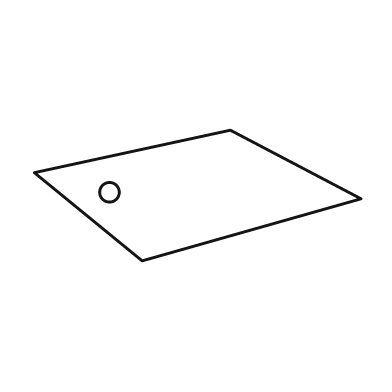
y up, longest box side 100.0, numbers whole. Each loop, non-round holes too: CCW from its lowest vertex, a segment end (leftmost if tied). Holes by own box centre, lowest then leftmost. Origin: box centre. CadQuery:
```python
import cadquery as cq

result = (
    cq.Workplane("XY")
    .moveTo(-17.0, -20.0)
    .lineTo(50.0, -1.0)
    .lineTo(10.0, 20.0)
    .lineTo(-50.0, 7.0)
    .close()
    .moveTo(-27.0, 1.0)
    .circle(3.0)
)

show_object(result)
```